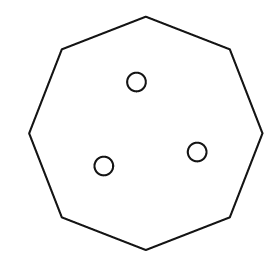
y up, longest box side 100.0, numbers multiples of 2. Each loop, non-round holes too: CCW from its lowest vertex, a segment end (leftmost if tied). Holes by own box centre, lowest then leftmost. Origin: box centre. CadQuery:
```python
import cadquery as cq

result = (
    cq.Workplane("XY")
    .moveTo(0.0, -50.0)
    .lineTo(36.0, -36.0)
    .lineTo(50.0, 0.0)
    .lineTo(36.0, 36.0)
    .lineTo(0.0, 50.0)
    .lineTo(-36.0, 36.0)
    .lineTo(-50.0, 0.0)
    .lineTo(-36.0, -36.0)
    .close()
    .moveTo(-18.0, -14.0)
    .circle(4.0)
    .moveTo(22.0, -8.0)
    .circle(4.0)
    .moveTo(-4.0, 22.0)
    .circle(4.0)
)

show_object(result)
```